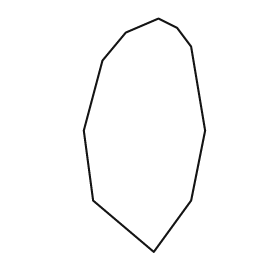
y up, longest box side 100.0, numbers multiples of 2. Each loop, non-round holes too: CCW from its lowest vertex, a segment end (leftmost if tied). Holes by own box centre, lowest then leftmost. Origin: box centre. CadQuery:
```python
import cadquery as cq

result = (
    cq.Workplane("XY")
    .moveTo(4.0, -50.0)
    .lineTo(20.0, -28.0)
    .lineTo(26.0, 2.0)
    .lineTo(20.0, 38.0)
    .lineTo(14.0, 46.0)
    .lineTo(6.0, 50.0)
    .lineTo(-8.0, 44.0)
    .lineTo(-18.0, 32.0)
    .lineTo(-26.0, 2.0)
    .lineTo(-22.0, -28.0)
    .close()
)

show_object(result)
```